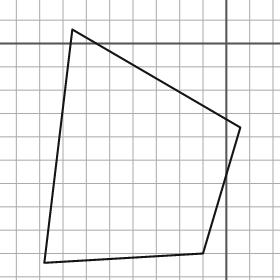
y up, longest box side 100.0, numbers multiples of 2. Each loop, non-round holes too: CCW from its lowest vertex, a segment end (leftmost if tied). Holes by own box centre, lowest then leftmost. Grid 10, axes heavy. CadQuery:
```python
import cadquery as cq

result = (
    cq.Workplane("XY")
    .moveTo(-78.0, -94.0)
    .lineTo(-10.0, -90.0)
    .lineTo(6.0, -36.0)
    .lineTo(-66.0, 6.0)
    .close()
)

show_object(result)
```